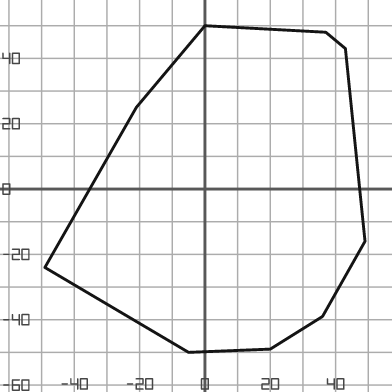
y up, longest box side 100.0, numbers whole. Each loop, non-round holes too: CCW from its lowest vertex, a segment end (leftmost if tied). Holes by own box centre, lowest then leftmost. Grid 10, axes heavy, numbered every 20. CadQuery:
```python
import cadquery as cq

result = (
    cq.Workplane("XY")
    .moveTo(-5.0, -50.0)
    .lineTo(20.0, -49.0)
    .lineTo(36.0, -39.0)
    .lineTo(49.0, -16.0)
    .lineTo(43.0, 43.0)
    .lineTo(37.0, 48.0)
    .lineTo(0.0, 50.0)
    .lineTo(-21.0, 25.0)
    .lineTo(-49.0, -24.0)
    .close()
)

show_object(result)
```